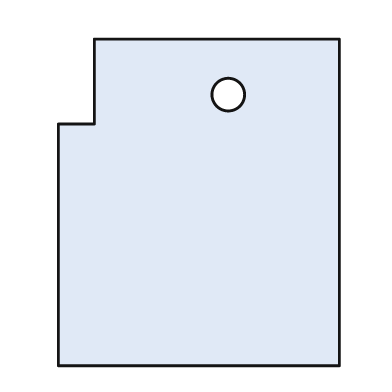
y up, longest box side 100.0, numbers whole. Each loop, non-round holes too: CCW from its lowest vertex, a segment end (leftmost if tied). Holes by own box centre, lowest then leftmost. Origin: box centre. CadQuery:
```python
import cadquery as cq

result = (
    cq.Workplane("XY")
    .moveTo(-43.0, -50.0)
    .lineTo(43.0, -50.0)
    .lineTo(43.0, 50.0)
    .lineTo(-32.0, 50.0)
    .lineTo(-32.0, 24.0)
    .lineTo(-43.0, 24.0)
    .close()
    .moveTo(9.0, 33.0)
    .circle(5.0)
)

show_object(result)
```